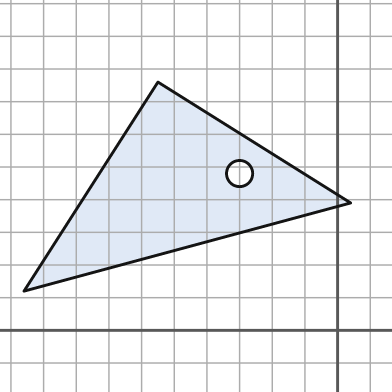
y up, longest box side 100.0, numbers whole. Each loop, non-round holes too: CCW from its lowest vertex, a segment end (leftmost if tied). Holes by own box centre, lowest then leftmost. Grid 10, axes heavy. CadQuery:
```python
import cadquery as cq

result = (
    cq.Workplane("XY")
    .moveTo(-96.0, 12.0)
    .lineTo(4.0, 39.0)
    .lineTo(-55.0, 76.0)
    .close()
    .moveTo(-30.0, 48.0)
    .circle(4.0)
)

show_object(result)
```